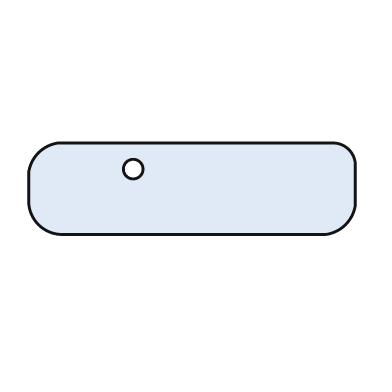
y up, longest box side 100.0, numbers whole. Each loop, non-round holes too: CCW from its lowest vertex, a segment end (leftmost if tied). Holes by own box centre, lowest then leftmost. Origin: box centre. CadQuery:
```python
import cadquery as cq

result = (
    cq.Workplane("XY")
    .moveTo(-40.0, -14.0)
    .lineTo(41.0, -14.0)
    .threePointArc((47.0, -11.0), (50.0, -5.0))
    .lineTo(50.0, 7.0)
    .threePointArc((48.0, 12.0), (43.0, 14.0))
    .lineTo(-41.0, 14.0)
    .threePointArc((-47.0, 11.0), (-50.0, 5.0))
    .lineTo(-50.0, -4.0)
    .threePointArc((-47.0, -11.0), (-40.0, -14.0))
    .close()
    .moveTo(-18.0, 6.0)
    .circle(3.0)
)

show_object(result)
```